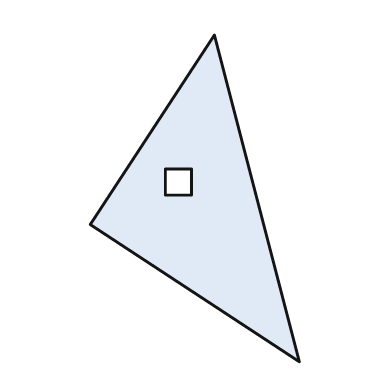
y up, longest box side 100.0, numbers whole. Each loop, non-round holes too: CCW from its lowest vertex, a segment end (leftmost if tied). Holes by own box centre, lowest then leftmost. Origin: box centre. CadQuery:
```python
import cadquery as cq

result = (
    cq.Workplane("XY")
    .moveTo(32.0, -50.0)
    .lineTo(6.0, 50.0)
    .lineTo(-32.0, -8.0)
    .close()
    .moveTo(-9.0, 1.0)
    .lineTo(-1.0, 1.0)
    .lineTo(-1.0, 9.0)
    .lineTo(-9.0, 9.0)
    .close()
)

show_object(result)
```